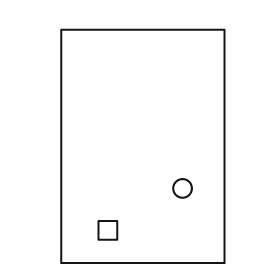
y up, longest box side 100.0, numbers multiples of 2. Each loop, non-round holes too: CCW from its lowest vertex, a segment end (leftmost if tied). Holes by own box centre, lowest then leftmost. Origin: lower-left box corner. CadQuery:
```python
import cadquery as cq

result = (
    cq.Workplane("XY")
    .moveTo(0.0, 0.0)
    .lineTo(70.0, 0.0)
    .lineTo(70.0, 100.0)
    .lineTo(0.0, 100.0)
    .close()
    .moveTo(16.0, 10.0)
    .lineTo(24.0, 10.0)
    .lineTo(24.0, 18.0)
    .lineTo(16.0, 18.0)
    .close()
    .moveTo(52.0, 32.0)
    .circle(4.0)
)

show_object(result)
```